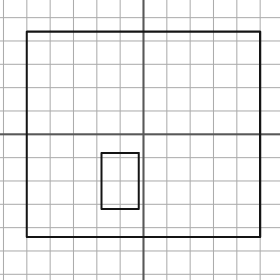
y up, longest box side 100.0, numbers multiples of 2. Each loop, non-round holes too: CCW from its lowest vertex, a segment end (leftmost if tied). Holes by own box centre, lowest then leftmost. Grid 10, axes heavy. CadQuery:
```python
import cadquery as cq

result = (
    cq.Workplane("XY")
    .moveTo(-50.0, -44.0)
    .lineTo(50.0, -44.0)
    .lineTo(50.0, 44.0)
    .lineTo(-50.0, 44.0)
    .close()
    .moveTo(-18.0, -32.0)
    .lineTo(-2.0, -32.0)
    .lineTo(-2.0, -8.0)
    .lineTo(-18.0, -8.0)
    .close()
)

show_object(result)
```